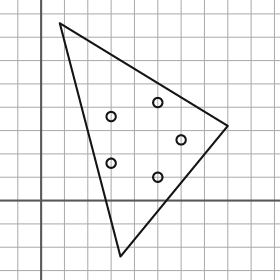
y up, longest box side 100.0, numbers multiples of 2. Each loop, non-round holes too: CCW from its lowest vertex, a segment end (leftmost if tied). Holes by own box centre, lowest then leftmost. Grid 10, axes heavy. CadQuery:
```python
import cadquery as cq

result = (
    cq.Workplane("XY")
    .moveTo(34.0, -24.0)
    .lineTo(80.0, 32.0)
    .lineTo(8.0, 76.0)
    .close()
    .moveTo(50.0, 10.0)
    .circle(2.0)
    .moveTo(30.0, 16.0)
    .circle(2.0)
    .moveTo(60.0, 26.0)
    .circle(2.0)
    .moveTo(30.0, 36.0)
    .circle(2.0)
    .moveTo(50.0, 42.0)
    .circle(2.0)
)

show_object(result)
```